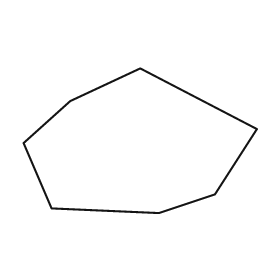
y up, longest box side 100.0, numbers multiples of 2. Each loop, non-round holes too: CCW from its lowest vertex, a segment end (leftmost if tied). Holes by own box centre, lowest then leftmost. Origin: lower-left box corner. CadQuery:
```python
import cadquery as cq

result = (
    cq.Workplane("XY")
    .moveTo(58.0, 0.0)
    .lineTo(82.0, 8.0)
    .lineTo(100.0, 36.0)
    .lineTo(50.0, 62.0)
    .lineTo(20.0, 48.0)
    .lineTo(0.0, 30.0)
    .lineTo(12.0, 2.0)
    .close()
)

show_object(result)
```